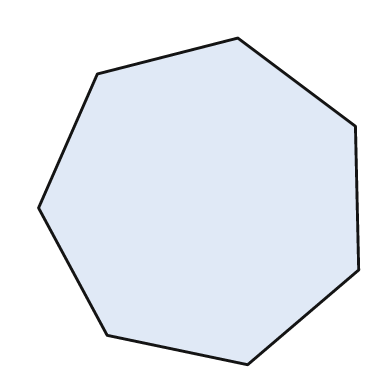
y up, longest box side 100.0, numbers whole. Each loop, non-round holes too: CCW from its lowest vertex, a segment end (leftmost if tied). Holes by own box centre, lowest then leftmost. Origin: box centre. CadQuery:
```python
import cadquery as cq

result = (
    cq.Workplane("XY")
    .moveTo(15.0, -50.0)
    .lineTo(49.0, -21.0)
    .lineTo(48.0, 23.0)
    .lineTo(12.0, 50.0)
    .lineTo(-31.0, 39.0)
    .lineTo(-49.0, -2.0)
    .lineTo(-28.0, -41.0)
    .close()
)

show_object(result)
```